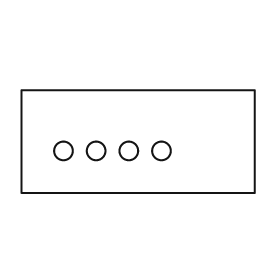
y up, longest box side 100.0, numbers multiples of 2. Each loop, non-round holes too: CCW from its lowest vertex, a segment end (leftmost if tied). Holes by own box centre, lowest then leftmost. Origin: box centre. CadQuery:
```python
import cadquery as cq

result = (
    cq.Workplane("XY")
    .moveTo(-50.0, -22.0)
    .lineTo(50.0, -22.0)
    .lineTo(50.0, 22.0)
    .lineTo(-50.0, 22.0)
    .close()
    .moveTo(-32.0, -4.0)
    .circle(4.0)
    .moveTo(-18.0, -4.0)
    .circle(4.0)
    .moveTo(-4.0, -4.0)
    .circle(4.0)
    .moveTo(10.0, -4.0)
    .circle(4.0)
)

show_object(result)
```